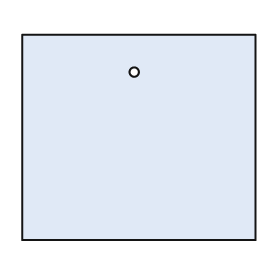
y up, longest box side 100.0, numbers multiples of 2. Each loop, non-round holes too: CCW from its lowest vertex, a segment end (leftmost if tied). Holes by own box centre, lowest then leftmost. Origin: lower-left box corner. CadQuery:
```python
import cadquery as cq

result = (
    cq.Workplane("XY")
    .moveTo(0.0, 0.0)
    .lineTo(100.0, 0.0)
    .lineTo(100.0, 88.0)
    .lineTo(0.0, 88.0)
    .close()
    .moveTo(48.0, 72.0)
    .circle(2.0)
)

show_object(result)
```